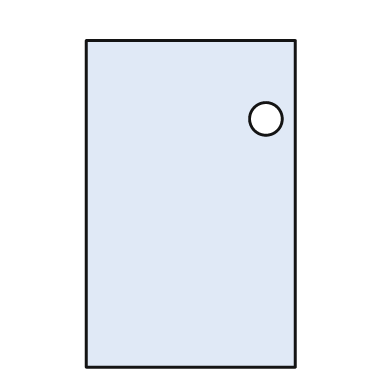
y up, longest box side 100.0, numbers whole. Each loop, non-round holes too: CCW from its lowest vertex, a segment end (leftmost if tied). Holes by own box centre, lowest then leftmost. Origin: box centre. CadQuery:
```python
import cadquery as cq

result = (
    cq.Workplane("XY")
    .moveTo(-32.0, -50.0)
    .lineTo(32.0, -50.0)
    .lineTo(32.0, 50.0)
    .lineTo(-32.0, 50.0)
    .close()
    .moveTo(23.0, 26.0)
    .circle(5.0)
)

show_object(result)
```